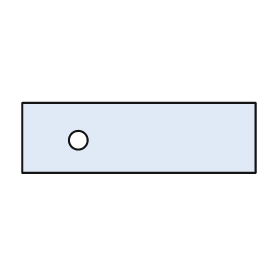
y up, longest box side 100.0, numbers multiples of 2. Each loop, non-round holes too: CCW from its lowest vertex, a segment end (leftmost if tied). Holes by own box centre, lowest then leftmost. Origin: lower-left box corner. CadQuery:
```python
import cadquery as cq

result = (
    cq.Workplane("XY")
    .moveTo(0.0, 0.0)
    .lineTo(100.0, 0.0)
    .lineTo(100.0, 30.0)
    .lineTo(0.0, 30.0)
    .close()
    .moveTo(24.0, 14.0)
    .circle(4.0)
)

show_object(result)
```